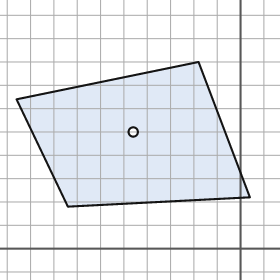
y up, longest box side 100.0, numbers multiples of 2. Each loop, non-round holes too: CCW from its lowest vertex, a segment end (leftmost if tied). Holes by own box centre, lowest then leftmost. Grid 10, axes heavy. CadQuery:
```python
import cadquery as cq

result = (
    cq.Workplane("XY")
    .moveTo(-74.0, 18.0)
    .lineTo(4.0, 22.0)
    .lineTo(-18.0, 80.0)
    .lineTo(-96.0, 64.0)
    .close()
    .moveTo(-46.0, 50.0)
    .circle(2.0)
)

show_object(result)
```